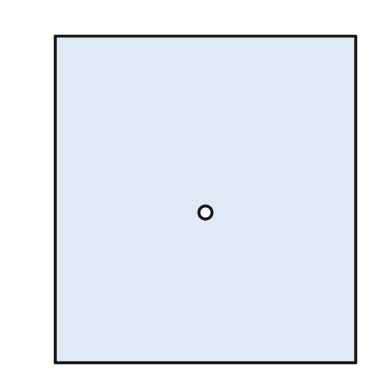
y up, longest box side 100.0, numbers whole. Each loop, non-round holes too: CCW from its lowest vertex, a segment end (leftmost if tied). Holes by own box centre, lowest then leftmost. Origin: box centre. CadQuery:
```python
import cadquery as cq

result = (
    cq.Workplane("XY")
    .moveTo(-46.0, -50.0)
    .lineTo(46.0, -50.0)
    .lineTo(46.0, 50.0)
    .lineTo(-46.0, 50.0)
    .close()
    .moveTo(0.0, -4.0)
    .circle(2.0)
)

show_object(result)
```